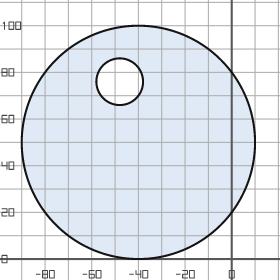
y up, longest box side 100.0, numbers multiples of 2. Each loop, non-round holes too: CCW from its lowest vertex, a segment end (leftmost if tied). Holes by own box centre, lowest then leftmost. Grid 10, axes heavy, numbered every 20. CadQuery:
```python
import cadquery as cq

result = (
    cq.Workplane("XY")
    .moveTo(-40.0, 50.0)
    .circle(50.0)
    .moveTo(-48.0, 76.0)
    .circle(10.0)
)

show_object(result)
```